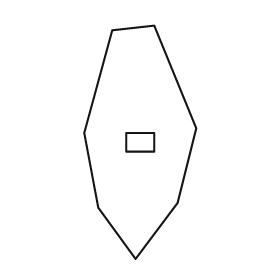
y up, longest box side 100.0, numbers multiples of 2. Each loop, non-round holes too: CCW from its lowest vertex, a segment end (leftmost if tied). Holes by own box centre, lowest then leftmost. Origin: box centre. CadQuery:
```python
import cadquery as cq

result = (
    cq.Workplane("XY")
    .moveTo(-2.0, -50.0)
    .lineTo(16.0, -26.0)
    .lineTo(24.0, 6.0)
    .lineTo(6.0, 50.0)
    .lineTo(-12.0, 48.0)
    .lineTo(-24.0, 4.0)
    .lineTo(-18.0, -28.0)
    .close()
    .moveTo(-6.0, -4.0)
    .lineTo(6.0, -4.0)
    .lineTo(6.0, 4.0)
    .lineTo(-6.0, 4.0)
    .close()
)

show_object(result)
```